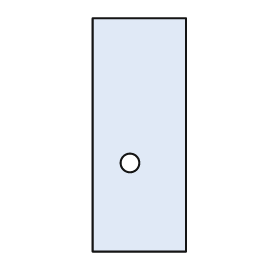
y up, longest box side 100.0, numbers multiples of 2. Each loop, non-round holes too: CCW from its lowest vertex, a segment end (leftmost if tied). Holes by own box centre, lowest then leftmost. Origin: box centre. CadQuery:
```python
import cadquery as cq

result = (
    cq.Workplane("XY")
    .moveTo(-20.0, -50.0)
    .lineTo(20.0, -50.0)
    .lineTo(20.0, 50.0)
    .lineTo(-20.0, 50.0)
    .close()
    .moveTo(-4.0, -12.0)
    .circle(4.0)
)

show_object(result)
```